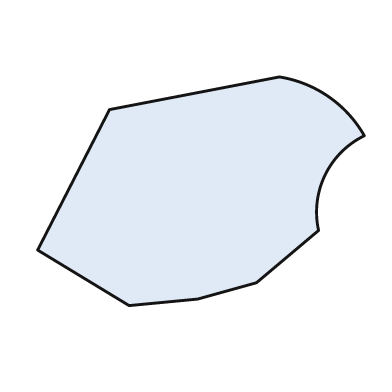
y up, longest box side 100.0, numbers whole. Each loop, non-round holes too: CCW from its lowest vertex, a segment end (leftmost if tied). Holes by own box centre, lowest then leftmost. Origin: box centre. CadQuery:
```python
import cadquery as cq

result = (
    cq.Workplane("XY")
    .moveTo(-22.0, -35.0)
    .lineTo(-1.0, -33.0)
    .lineTo(17.0, -28.0)
    .lineTo(36.0, -12.0)
    .threePointArc((38.0, 5.0), (50.0, 17.0))
    .threePointArc((39.0, 29.0), (24.0, 35.0))
    .lineTo(-28.0, 25.0)
    .lineTo(-50.0, -18.0)
    .close()
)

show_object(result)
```